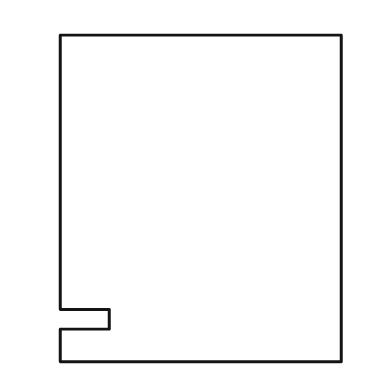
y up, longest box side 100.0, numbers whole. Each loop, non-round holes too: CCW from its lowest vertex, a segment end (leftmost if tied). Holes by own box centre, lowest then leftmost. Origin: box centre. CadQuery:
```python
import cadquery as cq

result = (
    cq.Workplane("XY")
    .moveTo(-43.0, -50.0)
    .lineTo(43.0, -50.0)
    .lineTo(43.0, 50.0)
    .lineTo(-43.0, 50.0)
    .lineTo(-43.0, -34.0)
    .lineTo(-28.0, -34.0)
    .lineTo(-28.0, -40.0)
    .lineTo(-43.0, -40.0)
    .close()
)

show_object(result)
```